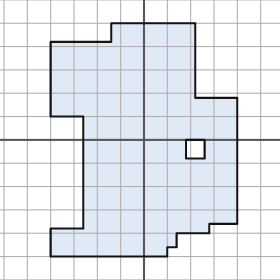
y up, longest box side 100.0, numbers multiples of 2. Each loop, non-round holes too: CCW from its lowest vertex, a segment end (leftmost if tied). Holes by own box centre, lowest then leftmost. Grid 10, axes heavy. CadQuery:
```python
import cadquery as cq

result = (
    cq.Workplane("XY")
    .moveTo(-40.0, -50.0)
    .lineTo(10.0, -50.0)
    .lineTo(10.0, -46.0)
    .lineTo(14.0, -46.0)
    .lineTo(14.0, -40.0)
    .lineTo(28.0, -40.0)
    .lineTo(28.0, -36.0)
    .lineTo(40.0, -36.0)
    .lineTo(40.0, 18.0)
    .lineTo(22.0, 18.0)
    .lineTo(22.0, 50.0)
    .lineTo(-14.0, 50.0)
    .lineTo(-14.0, 42.0)
    .lineTo(-40.0, 42.0)
    .lineTo(-40.0, 10.0)
    .lineTo(-26.0, 10.0)
    .lineTo(-26.0, -38.0)
    .lineTo(-40.0, -38.0)
    .close()
    .moveTo(18.0, -8.0)
    .lineTo(26.0, -8.0)
    .lineTo(26.0, 0.0)
    .lineTo(18.0, 0.0)
    .close()
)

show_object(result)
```